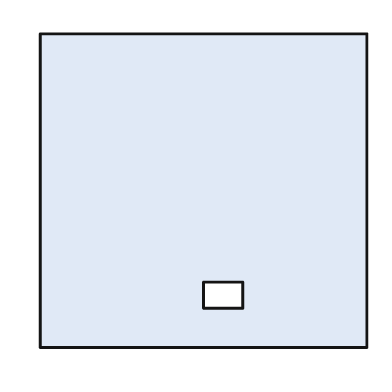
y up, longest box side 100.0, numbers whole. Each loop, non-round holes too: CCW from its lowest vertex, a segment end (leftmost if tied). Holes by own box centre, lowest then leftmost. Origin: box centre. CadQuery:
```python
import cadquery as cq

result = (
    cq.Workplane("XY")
    .moveTo(-50.0, -48.0)
    .lineTo(50.0, -48.0)
    .lineTo(50.0, 48.0)
    .lineTo(-50.0, 48.0)
    .close()
    .moveTo(0.0, -36.0)
    .lineTo(12.0, -36.0)
    .lineTo(12.0, -28.0)
    .lineTo(0.0, -28.0)
    .close()
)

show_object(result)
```